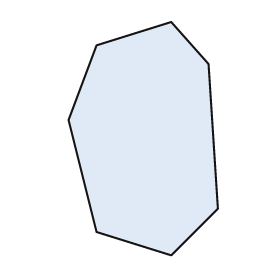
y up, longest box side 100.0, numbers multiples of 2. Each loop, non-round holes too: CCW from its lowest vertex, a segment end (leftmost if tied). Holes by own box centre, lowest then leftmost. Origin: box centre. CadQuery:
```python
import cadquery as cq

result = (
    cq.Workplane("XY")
    .moveTo(12.0, -50.0)
    .lineTo(32.0, -30.0)
    .lineTo(28.0, 32.0)
    .lineTo(12.0, 50.0)
    .lineTo(-20.0, 40.0)
    .lineTo(-32.0, 8.0)
    .lineTo(-20.0, -40.0)
    .close()
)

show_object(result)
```